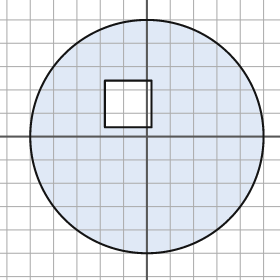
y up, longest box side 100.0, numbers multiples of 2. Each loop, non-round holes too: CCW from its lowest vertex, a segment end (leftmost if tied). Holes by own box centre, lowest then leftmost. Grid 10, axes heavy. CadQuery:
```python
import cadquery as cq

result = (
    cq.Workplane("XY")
    .moveTo(0.0, 0.0)
    .circle(50.0)
    .moveTo(-18.0, 4.0)
    .lineTo(2.0, 4.0)
    .lineTo(2.0, 24.0)
    .lineTo(-18.0, 24.0)
    .close()
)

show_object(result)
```